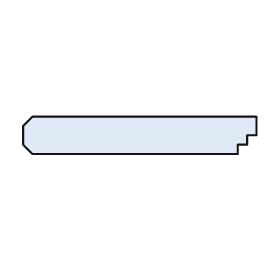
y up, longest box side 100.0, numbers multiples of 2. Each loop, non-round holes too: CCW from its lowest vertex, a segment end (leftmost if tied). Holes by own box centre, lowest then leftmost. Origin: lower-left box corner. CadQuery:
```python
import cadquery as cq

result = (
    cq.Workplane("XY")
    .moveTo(4.0, 0.0)
    .lineTo(92.0, 0.0)
    .lineTo(92.0, 4.0)
    .lineTo(96.0, 4.0)
    .lineTo(96.0, 8.0)
    .lineTo(100.0, 8.0)
    .lineTo(100.0, 16.0)
    .lineTo(4.0, 16.0)
    .lineTo(0.0, 12.0)
    .lineTo(0.0, 4.0)
    .close()
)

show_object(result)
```